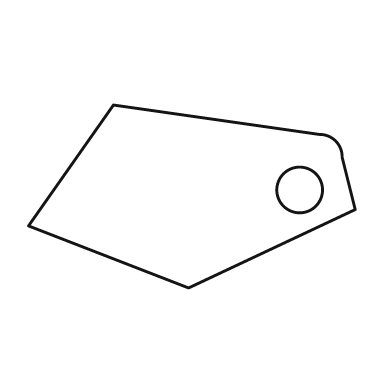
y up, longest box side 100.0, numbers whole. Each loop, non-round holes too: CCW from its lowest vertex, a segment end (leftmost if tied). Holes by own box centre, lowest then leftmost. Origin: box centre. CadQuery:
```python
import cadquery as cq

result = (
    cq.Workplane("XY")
    .moveTo(-1.0, -28.0)
    .lineTo(50.0, -4.0)
    .lineTo(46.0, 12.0)
    .threePointArc((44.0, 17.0), (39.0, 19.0))
    .lineTo(-24.0, 28.0)
    .lineTo(-50.0, -9.0)
    .close()
    .moveTo(33.0, 2.0)
    .circle(7.0)
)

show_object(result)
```